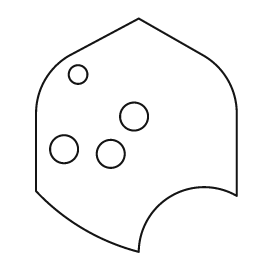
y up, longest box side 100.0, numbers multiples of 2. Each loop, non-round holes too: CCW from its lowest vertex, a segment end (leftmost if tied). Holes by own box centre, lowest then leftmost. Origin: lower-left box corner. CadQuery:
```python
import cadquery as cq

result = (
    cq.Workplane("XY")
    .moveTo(44.0, 0.0)
    .threePointArc((58.0, 24.0), (86.0, 24.0))
    .lineTo(86.0, 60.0)
    .threePointArc((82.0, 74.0), (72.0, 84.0))
    .lineTo(44.0, 100.0)
    .lineTo(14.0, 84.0)
    .threePointArc((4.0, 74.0), (0.0, 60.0))
    .lineTo(0.0, 26.0)
    .threePointArc((20.0, 10.0), (44.0, 0.0))
    .close()
    .moveTo(32.0, 42.0)
    .circle(6.0)
    .moveTo(12.0, 44.0)
    .circle(6.0)
    .moveTo(42.0, 58.0)
    .circle(6.0)
    .moveTo(18.0, 76.0)
    .circle(4.0)
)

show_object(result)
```